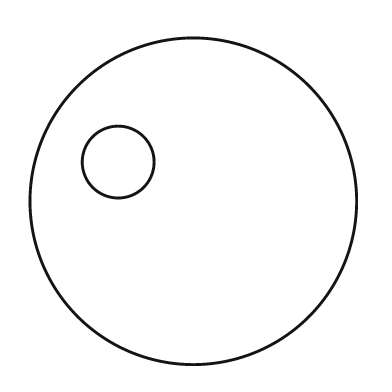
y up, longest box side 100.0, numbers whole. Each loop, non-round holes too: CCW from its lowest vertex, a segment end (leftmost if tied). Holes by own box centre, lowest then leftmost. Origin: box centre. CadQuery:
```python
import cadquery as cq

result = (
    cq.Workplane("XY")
    .moveTo(0.0, 0.0)
    .circle(50.0)
    .moveTo(-23.0, 12.0)
    .circle(11.0)
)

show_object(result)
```